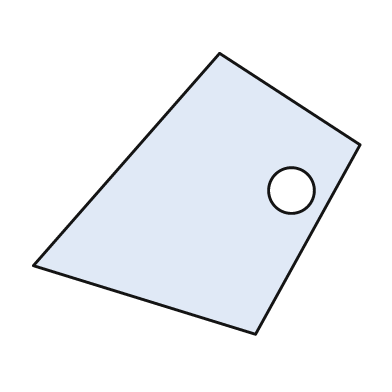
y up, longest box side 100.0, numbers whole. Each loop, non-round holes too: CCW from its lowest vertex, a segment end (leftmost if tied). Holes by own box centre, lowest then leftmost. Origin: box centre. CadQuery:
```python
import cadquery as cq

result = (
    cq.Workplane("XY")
    .moveTo(18.0, -43.0)
    .lineTo(50.0, 15.0)
    .lineTo(7.0, 43.0)
    .lineTo(-50.0, -22.0)
    .close()
    .moveTo(29.0, 1.0)
    .circle(7.0)
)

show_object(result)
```